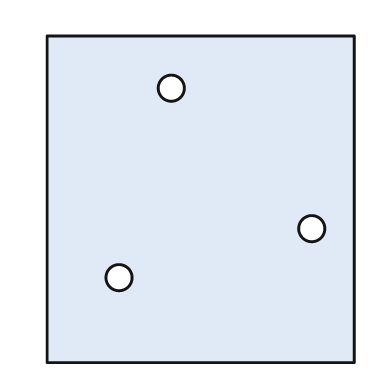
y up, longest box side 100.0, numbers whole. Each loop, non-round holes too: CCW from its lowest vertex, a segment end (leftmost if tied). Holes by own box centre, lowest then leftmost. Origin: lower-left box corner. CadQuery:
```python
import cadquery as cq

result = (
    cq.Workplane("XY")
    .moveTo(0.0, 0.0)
    .lineTo(94.0, 0.0)
    .lineTo(94.0, 100.0)
    .lineTo(0.0, 100.0)
    .close()
    .moveTo(22.0, 26.0)
    .circle(4.0)
    .moveTo(81.0, 41.0)
    .circle(4.0)
    .moveTo(38.0, 84.0)
    .circle(4.0)
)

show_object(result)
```